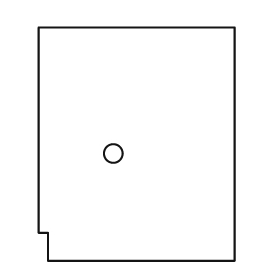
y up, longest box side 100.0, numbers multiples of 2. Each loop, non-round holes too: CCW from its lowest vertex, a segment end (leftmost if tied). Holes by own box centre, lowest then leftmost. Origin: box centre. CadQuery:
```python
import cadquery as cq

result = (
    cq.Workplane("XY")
    .moveTo(-38.0, -50.0)
    .lineTo(42.0, -50.0)
    .lineTo(42.0, 50.0)
    .lineTo(-42.0, 50.0)
    .lineTo(-42.0, -38.0)
    .lineTo(-38.0, -38.0)
    .close()
    .moveTo(-10.0, -4.0)
    .circle(4.0)
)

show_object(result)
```